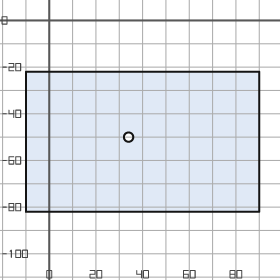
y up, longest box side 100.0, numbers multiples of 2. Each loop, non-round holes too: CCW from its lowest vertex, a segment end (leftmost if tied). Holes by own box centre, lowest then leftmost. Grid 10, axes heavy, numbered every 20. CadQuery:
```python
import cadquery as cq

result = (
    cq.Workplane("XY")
    .moveTo(-10.0, -82.0)
    .lineTo(90.0, -82.0)
    .lineTo(90.0, -22.0)
    .lineTo(-10.0, -22.0)
    .close()
    .moveTo(34.0, -50.0)
    .circle(2.0)
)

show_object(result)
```